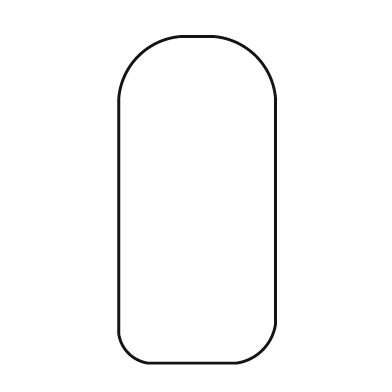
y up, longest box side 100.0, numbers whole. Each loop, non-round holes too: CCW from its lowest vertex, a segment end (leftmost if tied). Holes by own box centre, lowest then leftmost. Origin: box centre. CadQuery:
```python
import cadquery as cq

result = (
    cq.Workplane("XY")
    .moveTo(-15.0, -50.0)
    .lineTo(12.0, -50.0)
    .threePointArc((20.0, -46.0), (24.0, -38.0))
    .lineTo(24.0, 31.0)
    .threePointArc((18.0, 44.0), (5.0, 50.0))
    .lineTo(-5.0, 50.0)
    .threePointArc((-18.0, 44.0), (-24.0, 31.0))
    .lineTo(-24.0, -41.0)
    .threePointArc((-21.0, -47.0), (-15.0, -50.0))
    .close()
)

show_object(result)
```